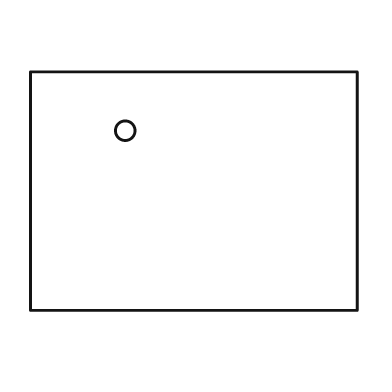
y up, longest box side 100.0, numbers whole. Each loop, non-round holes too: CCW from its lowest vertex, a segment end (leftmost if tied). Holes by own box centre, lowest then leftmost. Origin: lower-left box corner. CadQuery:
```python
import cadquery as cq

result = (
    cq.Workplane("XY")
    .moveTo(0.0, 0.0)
    .lineTo(100.0, 0.0)
    .lineTo(100.0, 73.0)
    .lineTo(0.0, 73.0)
    .close()
    .moveTo(29.0, 55.0)
    .circle(3.0)
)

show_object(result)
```